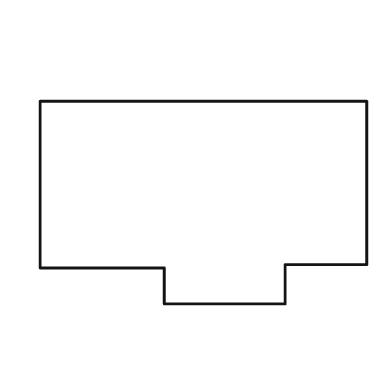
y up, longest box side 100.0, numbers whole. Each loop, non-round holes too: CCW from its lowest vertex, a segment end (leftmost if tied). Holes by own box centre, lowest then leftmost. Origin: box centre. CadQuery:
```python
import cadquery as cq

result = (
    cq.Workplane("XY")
    .moveTo(-12.0, -31.0)
    .lineTo(25.0, -31.0)
    .lineTo(25.0, -19.0)
    .lineTo(50.0, -19.0)
    .lineTo(50.0, 31.0)
    .lineTo(-50.0, 31.0)
    .lineTo(-50.0, -20.0)
    .lineTo(-12.0, -20.0)
    .close()
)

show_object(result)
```